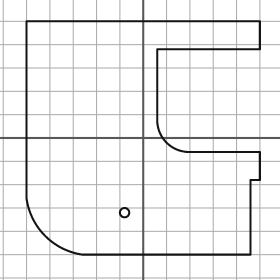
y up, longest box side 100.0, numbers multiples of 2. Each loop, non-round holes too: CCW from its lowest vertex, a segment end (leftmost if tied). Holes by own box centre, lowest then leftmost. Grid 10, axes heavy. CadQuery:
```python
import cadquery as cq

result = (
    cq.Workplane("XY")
    .moveTo(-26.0, -50.0)
    .lineTo(46.0, -50.0)
    .lineTo(46.0, -18.0)
    .lineTo(50.0, -18.0)
    .lineTo(50.0, -6.0)
    .lineTo(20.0, -6.0)
    .threePointArc((10.0, -2.0), (6.0, 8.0))
    .lineTo(6.0, 38.0)
    .lineTo(50.0, 38.0)
    .lineTo(50.0, 50.0)
    .lineTo(-50.0, 50.0)
    .lineTo(-50.0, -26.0)
    .threePointArc((-42.0, -42.0), (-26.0, -50.0))
    .close()
    .moveTo(-8.0, -32.0)
    .circle(2.0)
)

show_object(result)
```